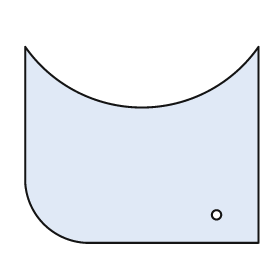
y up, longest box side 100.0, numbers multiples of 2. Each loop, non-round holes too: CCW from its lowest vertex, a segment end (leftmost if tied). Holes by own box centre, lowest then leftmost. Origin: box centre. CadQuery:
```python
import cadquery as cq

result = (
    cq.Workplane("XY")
    .moveTo(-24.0, -42.0)
    .lineTo(50.0, -42.0)
    .lineTo(50.0, 42.0)
    .threePointArc((0.0, 16.0), (-50.0, 42.0))
    .lineTo(-50.0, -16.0)
    .threePointArc((-42.0, -34.0), (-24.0, -42.0))
    .close()
    .moveTo(32.0, -30.0)
    .circle(2.0)
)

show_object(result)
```